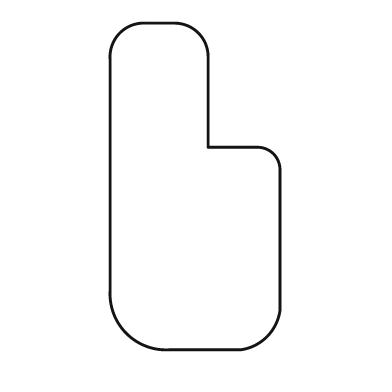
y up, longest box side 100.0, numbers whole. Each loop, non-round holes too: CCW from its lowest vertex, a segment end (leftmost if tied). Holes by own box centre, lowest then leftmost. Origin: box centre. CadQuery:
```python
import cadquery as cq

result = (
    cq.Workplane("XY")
    .moveTo(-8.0, -50.0)
    .lineTo(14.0, -50.0)
    .threePointArc((22.0, -46.0), (26.0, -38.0))
    .lineTo(26.0, 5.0)
    .threePointArc((24.0, 10.0), (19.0, 12.0))
    .lineTo(4.0, 12.0)
    .lineTo(4.0, 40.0)
    .threePointArc((1.0, 47.0), (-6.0, 50.0))
    .lineTo(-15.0, 50.0)
    .threePointArc((-23.0, 47.0), (-26.0, 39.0))
    .lineTo(-26.0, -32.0)
    .threePointArc((-21.0, -45.0), (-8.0, -50.0))
    .close()
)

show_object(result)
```